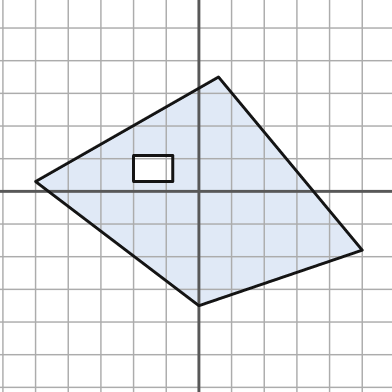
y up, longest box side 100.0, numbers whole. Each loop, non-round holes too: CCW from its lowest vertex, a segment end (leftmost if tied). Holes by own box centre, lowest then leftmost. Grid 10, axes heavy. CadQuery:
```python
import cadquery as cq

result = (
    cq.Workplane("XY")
    .moveTo(0.0, -35.0)
    .lineTo(50.0, -18.0)
    .lineTo(6.0, 35.0)
    .lineTo(-50.0, 3.0)
    .close()
    .moveTo(-20.0, 3.0)
    .lineTo(-8.0, 3.0)
    .lineTo(-8.0, 11.0)
    .lineTo(-20.0, 11.0)
    .close()
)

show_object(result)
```